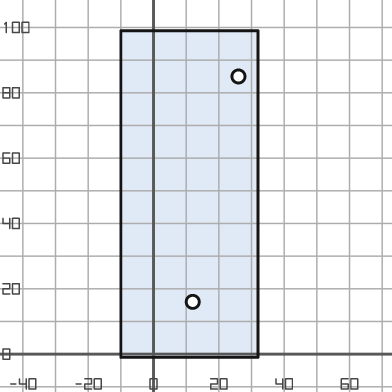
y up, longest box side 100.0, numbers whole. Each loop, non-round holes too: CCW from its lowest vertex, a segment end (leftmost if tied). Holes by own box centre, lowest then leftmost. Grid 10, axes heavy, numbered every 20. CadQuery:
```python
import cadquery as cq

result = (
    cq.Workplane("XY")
    .moveTo(-10.0, -1.0)
    .lineTo(32.0, -1.0)
    .lineTo(32.0, 99.0)
    .lineTo(-10.0, 99.0)
    .close()
    .moveTo(12.0, 16.0)
    .circle(2.0)
    .moveTo(26.0, 85.0)
    .circle(2.0)
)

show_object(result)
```